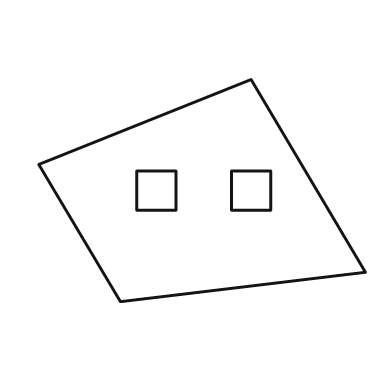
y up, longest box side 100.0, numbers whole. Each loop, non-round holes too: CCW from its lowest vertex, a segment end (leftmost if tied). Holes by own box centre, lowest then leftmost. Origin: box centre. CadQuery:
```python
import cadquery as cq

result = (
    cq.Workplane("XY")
    .moveTo(-25.0, -34.0)
    .lineTo(50.0, -25.0)
    .lineTo(15.0, 34.0)
    .lineTo(-50.0, 8.0)
    .close()
    .moveTo(-20.0, -6.0)
    .lineTo(-8.0, -6.0)
    .lineTo(-8.0, 6.0)
    .lineTo(-20.0, 6.0)
    .close()
    .moveTo(9.0, -6.0)
    .lineTo(21.0, -6.0)
    .lineTo(21.0, 6.0)
    .lineTo(9.0, 6.0)
    .close()
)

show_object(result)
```